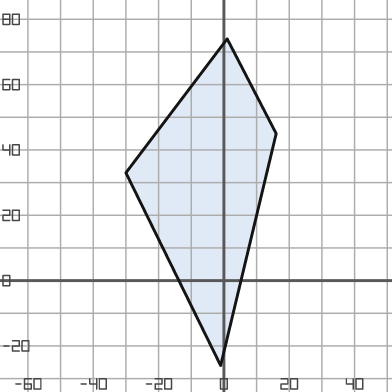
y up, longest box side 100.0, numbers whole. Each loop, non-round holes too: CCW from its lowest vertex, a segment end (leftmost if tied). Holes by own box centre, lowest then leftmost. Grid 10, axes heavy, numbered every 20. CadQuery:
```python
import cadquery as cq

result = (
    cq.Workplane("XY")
    .moveTo(-1.0, -26.0)
    .lineTo(16.0, 45.0)
    .lineTo(1.0, 74.0)
    .lineTo(-30.0, 33.0)
    .close()
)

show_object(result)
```